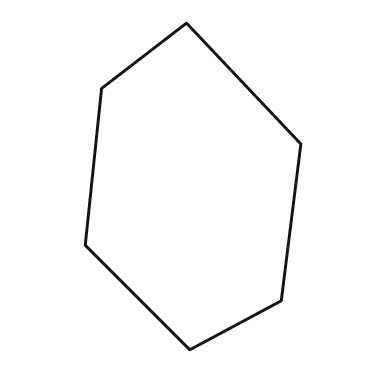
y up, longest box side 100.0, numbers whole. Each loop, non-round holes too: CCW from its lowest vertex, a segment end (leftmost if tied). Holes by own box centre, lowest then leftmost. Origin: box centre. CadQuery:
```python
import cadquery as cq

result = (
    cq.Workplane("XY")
    .moveTo(-1.0, -50.0)
    .lineTo(27.0, -35.0)
    .lineTo(33.0, 13.0)
    .lineTo(-2.0, 50.0)
    .lineTo(-28.0, 30.0)
    .lineTo(-33.0, -18.0)
    .close()
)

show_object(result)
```